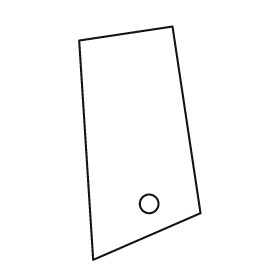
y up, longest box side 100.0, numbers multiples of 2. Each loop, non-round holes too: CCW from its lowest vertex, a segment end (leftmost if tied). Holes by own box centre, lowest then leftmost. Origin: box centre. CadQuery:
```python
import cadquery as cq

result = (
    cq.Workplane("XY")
    .moveTo(-20.0, -50.0)
    .lineTo(26.0, -30.0)
    .lineTo(14.0, 50.0)
    .lineTo(-26.0, 44.0)
    .close()
    .moveTo(4.0, -26.0)
    .circle(4.0)
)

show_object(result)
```